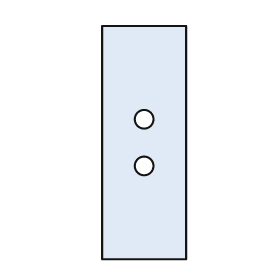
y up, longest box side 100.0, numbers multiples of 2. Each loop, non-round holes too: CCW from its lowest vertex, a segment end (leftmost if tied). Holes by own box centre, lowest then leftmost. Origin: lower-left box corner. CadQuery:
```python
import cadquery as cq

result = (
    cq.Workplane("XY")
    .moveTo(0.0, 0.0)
    .lineTo(36.0, 0.0)
    .lineTo(36.0, 100.0)
    .lineTo(0.0, 100.0)
    .close()
    .moveTo(18.0, 40.0)
    .circle(4.0)
    .moveTo(18.0, 60.0)
    .circle(4.0)
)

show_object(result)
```